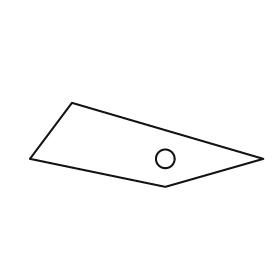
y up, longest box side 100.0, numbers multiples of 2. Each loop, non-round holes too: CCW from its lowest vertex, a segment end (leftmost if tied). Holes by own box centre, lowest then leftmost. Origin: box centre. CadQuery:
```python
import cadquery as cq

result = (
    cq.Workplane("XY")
    .moveTo(8.0, -18.0)
    .lineTo(50.0, -6.0)
    .lineTo(-32.0, 18.0)
    .lineTo(-50.0, -6.0)
    .close()
    .moveTo(8.0, -6.0)
    .circle(4.0)
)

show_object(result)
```